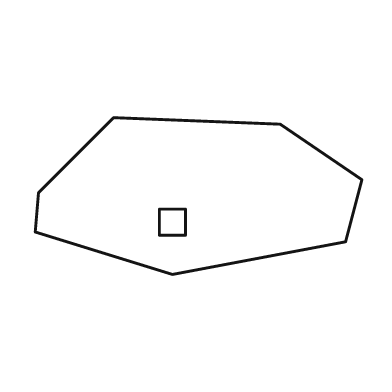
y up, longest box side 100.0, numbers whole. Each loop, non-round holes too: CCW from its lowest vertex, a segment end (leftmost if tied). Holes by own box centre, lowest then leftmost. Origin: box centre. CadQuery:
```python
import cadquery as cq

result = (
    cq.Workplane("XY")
    .moveTo(-8.0, -24.0)
    .lineTo(45.0, -14.0)
    .lineTo(50.0, 5.0)
    .lineTo(25.0, 22.0)
    .lineTo(-26.0, 24.0)
    .lineTo(-49.0, 1.0)
    .lineTo(-50.0, -11.0)
    .close()
    .moveTo(-12.0, -12.0)
    .lineTo(-4.0, -12.0)
    .lineTo(-4.0, -4.0)
    .lineTo(-12.0, -4.0)
    .close()
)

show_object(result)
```